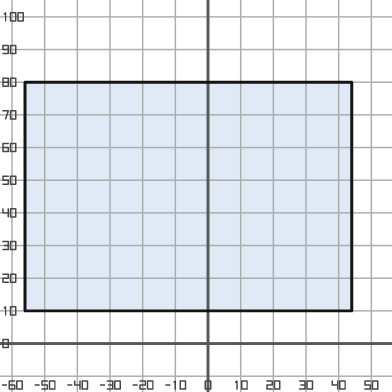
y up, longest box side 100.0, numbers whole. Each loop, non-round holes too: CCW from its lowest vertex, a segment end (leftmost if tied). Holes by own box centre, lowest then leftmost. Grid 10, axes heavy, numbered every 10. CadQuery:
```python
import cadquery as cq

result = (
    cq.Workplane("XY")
    .moveTo(-56.0, 10.0)
    .lineTo(44.0, 10.0)
    .lineTo(44.0, 80.0)
    .lineTo(-56.0, 80.0)
    .close()
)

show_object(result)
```